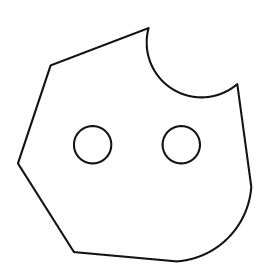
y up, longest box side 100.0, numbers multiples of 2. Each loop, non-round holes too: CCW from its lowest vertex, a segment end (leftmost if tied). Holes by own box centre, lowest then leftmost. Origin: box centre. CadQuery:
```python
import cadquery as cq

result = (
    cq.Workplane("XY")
    .moveTo(18.0, -50.0)
    .threePointArc((40.0, -40.0), (50.0, -18.0))
    .lineTo(44.0, 26.0)
    .threePointArc((16.0, 24.0), (6.0, 50.0))
    .lineTo(-36.0, 34.0)
    .lineTo(-50.0, -8.0)
    .lineTo(-26.0, -46.0)
    .close()
    .moveTo(-18.0, 0.0)
    .circle(8.0)
    .moveTo(20.0, 0.0)
    .circle(8.0)
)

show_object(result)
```